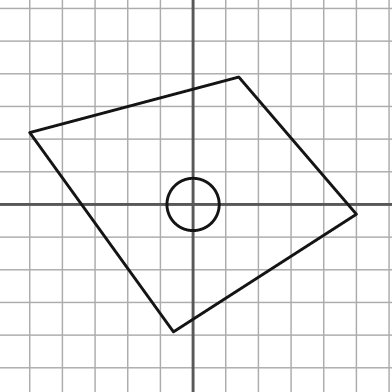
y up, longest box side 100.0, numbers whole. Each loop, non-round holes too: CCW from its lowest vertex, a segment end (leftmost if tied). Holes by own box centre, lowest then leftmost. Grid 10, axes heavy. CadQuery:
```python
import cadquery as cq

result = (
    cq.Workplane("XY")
    .moveTo(-6.0, -39.0)
    .lineTo(50.0, -3.0)
    .lineTo(14.0, 39.0)
    .lineTo(-50.0, 22.0)
    .close()
    .moveTo(0.0, 0.0)
    .circle(8.0)
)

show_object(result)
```